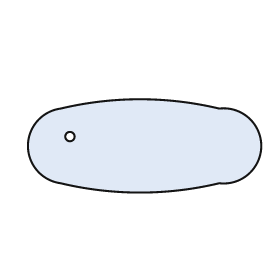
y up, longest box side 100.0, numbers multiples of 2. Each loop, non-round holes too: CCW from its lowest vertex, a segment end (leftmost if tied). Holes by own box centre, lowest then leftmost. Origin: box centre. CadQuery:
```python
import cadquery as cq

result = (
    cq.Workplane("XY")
    .moveTo(-36.0, -16.0)
    .threePointArc((-2.0, -20.0), (32.0, -16.0))
    .threePointArc((50.0, 0.0), (32.0, 16.0))
    .threePointArc((-2.0, 20.0), (-36.0, 16.0))
    .threePointArc((-50.0, 0.0), (-36.0, -16.0))
    .close()
    .moveTo(-32.0, 4.0)
    .circle(2.0)
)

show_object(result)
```